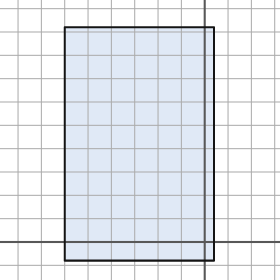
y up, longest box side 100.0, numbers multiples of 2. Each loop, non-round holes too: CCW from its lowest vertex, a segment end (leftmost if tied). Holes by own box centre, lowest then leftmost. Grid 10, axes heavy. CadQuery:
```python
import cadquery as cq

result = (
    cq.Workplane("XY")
    .moveTo(-60.0, -8.0)
    .lineTo(4.0, -8.0)
    .lineTo(4.0, 92.0)
    .lineTo(-60.0, 92.0)
    .close()
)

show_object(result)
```